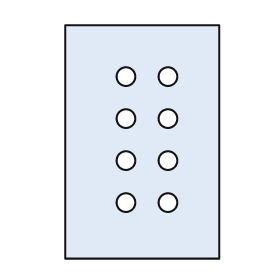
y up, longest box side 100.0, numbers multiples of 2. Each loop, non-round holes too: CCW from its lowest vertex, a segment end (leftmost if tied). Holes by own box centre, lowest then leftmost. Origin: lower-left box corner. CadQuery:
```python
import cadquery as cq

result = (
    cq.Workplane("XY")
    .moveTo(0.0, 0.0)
    .lineTo(66.0, 0.0)
    .lineTo(66.0, 100.0)
    .lineTo(0.0, 100.0)
    .close()
    .moveTo(26.0, 24.0)
    .circle(4.0)
    .moveTo(44.0, 24.0)
    .circle(4.0)
    .moveTo(26.0, 42.0)
    .circle(4.0)
    .moveTo(44.0, 42.0)
    .circle(4.0)
    .moveTo(26.0, 60.0)
    .circle(4.0)
    .moveTo(44.0, 60.0)
    .circle(4.0)
    .moveTo(26.0, 78.0)
    .circle(4.0)
    .moveTo(44.0, 78.0)
    .circle(4.0)
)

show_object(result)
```